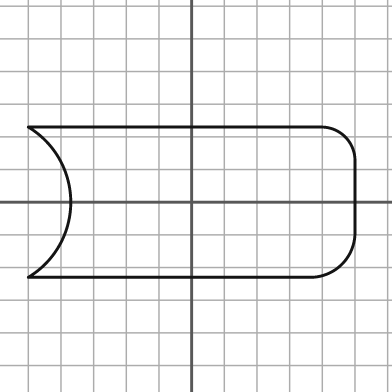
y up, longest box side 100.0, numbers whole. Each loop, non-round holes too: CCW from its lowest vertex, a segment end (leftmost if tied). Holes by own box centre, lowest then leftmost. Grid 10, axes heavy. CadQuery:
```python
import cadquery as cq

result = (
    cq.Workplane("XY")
    .moveTo(-50.0, -23.0)
    .lineTo(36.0, -23.0)
    .threePointArc((46.0, -19.0), (50.0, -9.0))
    .lineTo(50.0, 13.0)
    .threePointArc((47.0, 20.0), (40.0, 23.0))
    .lineTo(-50.0, 23.0)
    .threePointArc((-37.0, 0.0), (-50.0, -23.0))
    .close()
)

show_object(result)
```